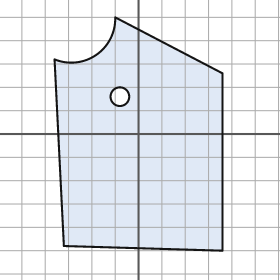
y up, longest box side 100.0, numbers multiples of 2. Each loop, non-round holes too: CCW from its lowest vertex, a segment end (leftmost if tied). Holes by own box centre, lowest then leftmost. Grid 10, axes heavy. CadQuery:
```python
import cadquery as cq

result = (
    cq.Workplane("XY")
    .moveTo(36.0, -50.0)
    .lineTo(36.0, 26.0)
    .lineTo(-10.0, 50.0)
    .threePointArc((-18.0, 34.0), (-36.0, 32.0))
    .lineTo(-32.0, -48.0)
    .close()
    .moveTo(-8.0, 16.0)
    .circle(4.0)
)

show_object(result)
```